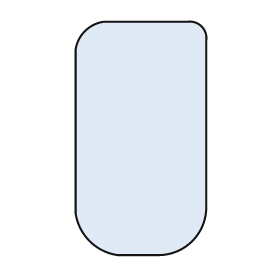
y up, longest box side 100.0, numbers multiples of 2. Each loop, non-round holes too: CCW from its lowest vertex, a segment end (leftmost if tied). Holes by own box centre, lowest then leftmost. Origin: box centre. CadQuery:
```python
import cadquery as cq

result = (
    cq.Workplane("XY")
    .moveTo(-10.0, -50.0)
    .lineTo(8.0, -50.0)
    .threePointArc((22.0, -44.0), (28.0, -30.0))
    .lineTo(28.0, 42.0)
    .threePointArc((26.0, 48.0), (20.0, 50.0))
    .lineTo(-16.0, 50.0)
    .threePointArc((-24.0, 46.0), (-28.0, 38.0))
    .lineTo(-28.0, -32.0)
    .threePointArc((-22.0, -44.0), (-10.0, -50.0))
    .close()
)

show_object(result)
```